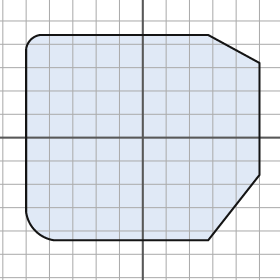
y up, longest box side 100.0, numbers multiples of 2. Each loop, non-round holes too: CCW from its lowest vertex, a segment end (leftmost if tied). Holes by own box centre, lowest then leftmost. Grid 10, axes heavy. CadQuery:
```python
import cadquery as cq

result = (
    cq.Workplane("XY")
    .moveTo(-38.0, -44.0)
    .lineTo(28.0, -44.0)
    .lineTo(50.0, -16.0)
    .lineTo(50.0, 32.0)
    .lineTo(28.0, 44.0)
    .lineTo(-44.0, 44.0)
    .threePointArc((-48.0, 42.0), (-50.0, 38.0))
    .lineTo(-50.0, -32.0)
    .threePointArc((-46.0, -40.0), (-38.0, -44.0))
    .close()
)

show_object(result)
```